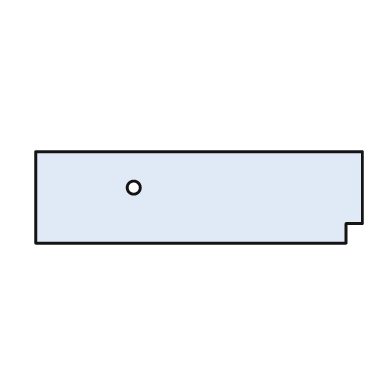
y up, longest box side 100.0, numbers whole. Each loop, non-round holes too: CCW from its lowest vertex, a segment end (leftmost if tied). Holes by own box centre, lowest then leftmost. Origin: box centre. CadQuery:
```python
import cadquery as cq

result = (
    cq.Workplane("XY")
    .moveTo(-50.0, -14.0)
    .lineTo(45.0, -14.0)
    .lineTo(45.0, -8.0)
    .lineTo(50.0, -8.0)
    .lineTo(50.0, 14.0)
    .lineTo(-50.0, 14.0)
    .close()
    .moveTo(-20.0, 3.0)
    .circle(2.0)
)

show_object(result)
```